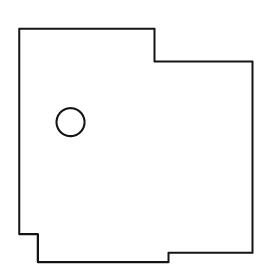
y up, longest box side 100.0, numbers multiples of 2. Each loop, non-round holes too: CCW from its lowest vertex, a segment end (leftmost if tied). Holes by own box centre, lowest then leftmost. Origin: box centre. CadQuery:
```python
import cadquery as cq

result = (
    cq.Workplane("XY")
    .moveTo(-42.0, -50.0)
    .lineTo(14.0, -50.0)
    .lineTo(14.0, -46.0)
    .lineTo(50.0, -46.0)
    .lineTo(50.0, 36.0)
    .lineTo(8.0, 36.0)
    .lineTo(8.0, 50.0)
    .lineTo(-50.0, 50.0)
    .lineTo(-50.0, -38.0)
    .lineTo(-42.0, -38.0)
    .close()
    .moveTo(-28.0, 10.0)
    .circle(6.0)
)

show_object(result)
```